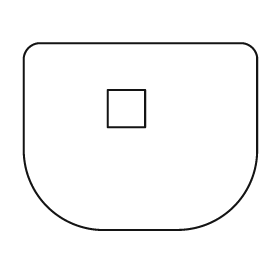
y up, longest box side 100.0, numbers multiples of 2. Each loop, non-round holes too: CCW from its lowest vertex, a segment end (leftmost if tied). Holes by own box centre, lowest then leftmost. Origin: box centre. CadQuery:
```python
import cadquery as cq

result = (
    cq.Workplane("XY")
    .moveTo(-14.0, -40.0)
    .lineTo(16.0, -40.0)
    .threePointArc((40.0, -30.0), (50.0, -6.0))
    .lineTo(50.0, 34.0)
    .threePointArc((48.0, 38.0), (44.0, 40.0))
    .lineTo(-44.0, 40.0)
    .threePointArc((-48.0, 38.0), (-50.0, 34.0))
    .lineTo(-50.0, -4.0)
    .threePointArc((-40.0, -30.0), (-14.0, -40.0))
    .close()
    .moveTo(-14.0, 4.0)
    .lineTo(2.0, 4.0)
    .lineTo(2.0, 20.0)
    .lineTo(-14.0, 20.0)
    .close()
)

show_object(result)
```